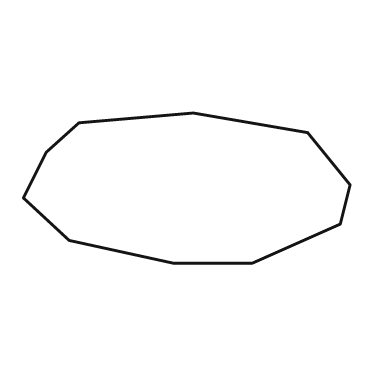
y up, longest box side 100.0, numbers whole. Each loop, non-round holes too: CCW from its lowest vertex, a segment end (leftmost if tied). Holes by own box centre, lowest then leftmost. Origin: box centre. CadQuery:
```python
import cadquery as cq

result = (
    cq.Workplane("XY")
    .moveTo(-4.0, -23.0)
    .lineTo(20.0, -23.0)
    .lineTo(47.0, -11.0)
    .lineTo(50.0, 1.0)
    .lineTo(37.0, 17.0)
    .lineTo(2.0, 23.0)
    .lineTo(-33.0, 20.0)
    .lineTo(-43.0, 11.0)
    .lineTo(-50.0, -3.0)
    .lineTo(-36.0, -16.0)
    .close()
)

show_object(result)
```